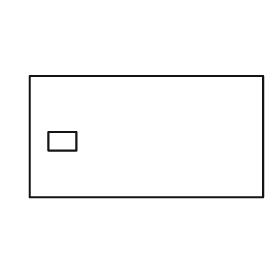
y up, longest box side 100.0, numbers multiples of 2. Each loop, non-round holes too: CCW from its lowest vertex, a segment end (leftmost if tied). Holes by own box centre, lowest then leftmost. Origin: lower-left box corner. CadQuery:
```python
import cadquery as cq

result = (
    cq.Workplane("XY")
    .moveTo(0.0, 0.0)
    .lineTo(100.0, 0.0)
    .lineTo(100.0, 52.0)
    .lineTo(0.0, 52.0)
    .close()
    .moveTo(8.0, 20.0)
    .lineTo(20.0, 20.0)
    .lineTo(20.0, 28.0)
    .lineTo(8.0, 28.0)
    .close()
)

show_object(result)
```